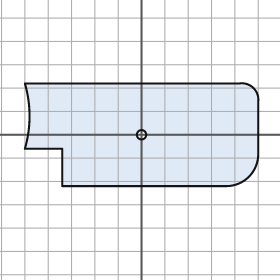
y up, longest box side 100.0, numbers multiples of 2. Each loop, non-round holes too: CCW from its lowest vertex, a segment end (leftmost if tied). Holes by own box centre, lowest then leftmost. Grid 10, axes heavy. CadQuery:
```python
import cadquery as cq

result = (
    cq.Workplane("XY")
    .moveTo(-34.0, -22.0)
    .lineTo(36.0, -22.0)
    .threePointArc((46.0, -18.0), (50.0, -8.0))
    .lineTo(50.0, 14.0)
    .threePointArc((48.0, 20.0), (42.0, 22.0))
    .lineTo(-50.0, 22.0)
    .threePointArc((-48.0, 8.0), (-50.0, -6.0))
    .lineTo(-34.0, -6.0)
    .close()
    .moveTo(0.0, 0.0)
    .circle(2.0)
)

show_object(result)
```